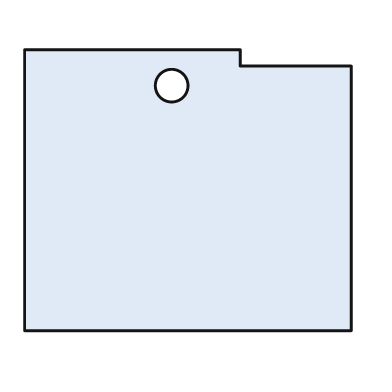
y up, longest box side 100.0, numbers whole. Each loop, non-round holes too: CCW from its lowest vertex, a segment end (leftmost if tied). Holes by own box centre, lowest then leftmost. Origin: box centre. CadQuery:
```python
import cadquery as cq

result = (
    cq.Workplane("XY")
    .moveTo(-50.0, -43.0)
    .lineTo(50.0, -43.0)
    .lineTo(50.0, 38.0)
    .lineTo(16.0, 38.0)
    .lineTo(16.0, 43.0)
    .lineTo(-50.0, 43.0)
    .close()
    .moveTo(-5.0, 32.0)
    .circle(5.0)
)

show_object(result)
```